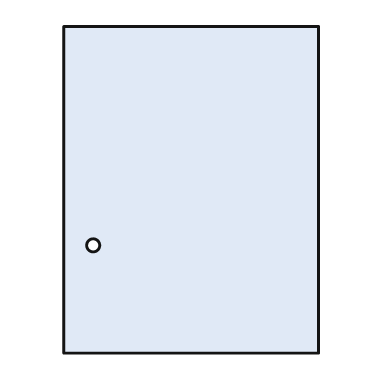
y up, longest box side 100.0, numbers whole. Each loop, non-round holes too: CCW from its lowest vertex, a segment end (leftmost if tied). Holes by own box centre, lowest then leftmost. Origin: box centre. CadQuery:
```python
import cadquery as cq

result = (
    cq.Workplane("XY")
    .moveTo(-39.0, -50.0)
    .lineTo(39.0, -50.0)
    .lineTo(39.0, 50.0)
    .lineTo(-39.0, 50.0)
    .close()
    .moveTo(-30.0, -17.0)
    .circle(2.0)
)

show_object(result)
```